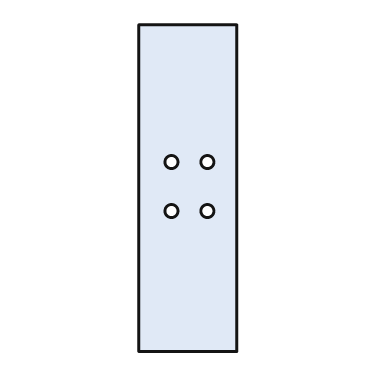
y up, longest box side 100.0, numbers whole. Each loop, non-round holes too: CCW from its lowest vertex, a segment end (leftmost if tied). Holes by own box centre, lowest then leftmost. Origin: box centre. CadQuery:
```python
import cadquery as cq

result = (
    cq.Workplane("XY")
    .moveTo(-15.0, -50.0)
    .lineTo(15.0, -50.0)
    .lineTo(15.0, 50.0)
    .lineTo(-15.0, 50.0)
    .close()
    .moveTo(-5.0, -7.0)
    .circle(2.0)
    .moveTo(6.0, -7.0)
    .circle(2.0)
    .moveTo(-5.0, 8.0)
    .circle(2.0)
    .moveTo(6.0, 8.0)
    .circle(2.0)
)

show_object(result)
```